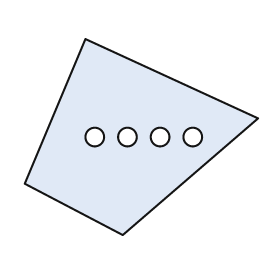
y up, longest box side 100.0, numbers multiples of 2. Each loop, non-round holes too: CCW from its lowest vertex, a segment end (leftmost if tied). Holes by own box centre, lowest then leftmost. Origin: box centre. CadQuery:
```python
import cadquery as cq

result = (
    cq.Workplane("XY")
    .moveTo(-8.0, -42.0)
    .lineTo(50.0, 8.0)
    .lineTo(-24.0, 42.0)
    .lineTo(-50.0, -20.0)
    .close()
    .moveTo(-20.0, 0.0)
    .circle(4.0)
    .moveTo(-6.0, 0.0)
    .circle(4.0)
    .moveTo(8.0, 0.0)
    .circle(4.0)
    .moveTo(22.0, 0.0)
    .circle(4.0)
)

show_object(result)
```